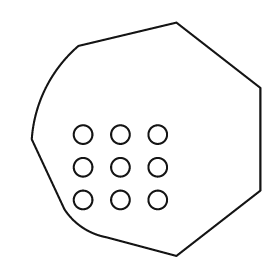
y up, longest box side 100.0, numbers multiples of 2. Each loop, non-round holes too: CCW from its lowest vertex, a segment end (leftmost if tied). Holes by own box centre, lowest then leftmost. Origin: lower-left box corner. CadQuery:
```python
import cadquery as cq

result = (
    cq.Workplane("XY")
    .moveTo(62.0, 0.0)
    .lineTo(98.0, 28.0)
    .lineTo(98.0, 72.0)
    .lineTo(62.0, 100.0)
    .lineTo(20.0, 90.0)
    .threePointArc((6.0, 72.0), (0.0, 50.0))
    .lineTo(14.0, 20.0)
    .threePointArc((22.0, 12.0), (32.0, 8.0))
    .close()
    .moveTo(22.0, 24.0)
    .circle(4.0)
    .moveTo(38.0, 24.0)
    .circle(4.0)
    .moveTo(54.0, 24.0)
    .circle(4.0)
    .moveTo(22.0, 38.0)
    .circle(4.0)
    .moveTo(38.0, 38.0)
    .circle(4.0)
    .moveTo(54.0, 38.0)
    .circle(4.0)
    .moveTo(22.0, 52.0)
    .circle(4.0)
    .moveTo(38.0, 52.0)
    .circle(4.0)
    .moveTo(54.0, 52.0)
    .circle(4.0)
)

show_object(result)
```